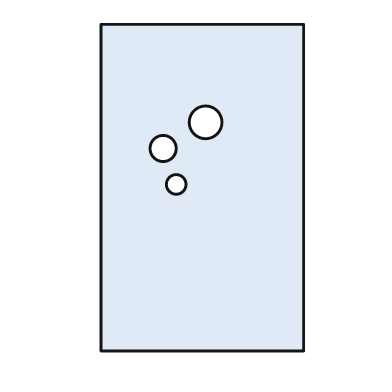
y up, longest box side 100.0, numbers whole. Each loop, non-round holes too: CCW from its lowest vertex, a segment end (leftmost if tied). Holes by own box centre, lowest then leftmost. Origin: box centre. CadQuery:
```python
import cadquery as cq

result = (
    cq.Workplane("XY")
    .moveTo(-31.0, -50.0)
    .lineTo(31.0, -50.0)
    .lineTo(31.0, 50.0)
    .lineTo(-31.0, 50.0)
    .close()
    .moveTo(-8.0, 1.0)
    .circle(3.0)
    .moveTo(-12.0, 12.0)
    .circle(4.0)
    .moveTo(1.0, 20.0)
    .circle(5.0)
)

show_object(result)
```